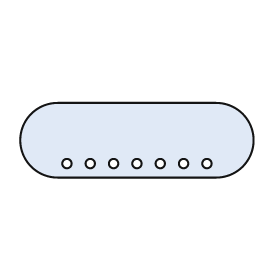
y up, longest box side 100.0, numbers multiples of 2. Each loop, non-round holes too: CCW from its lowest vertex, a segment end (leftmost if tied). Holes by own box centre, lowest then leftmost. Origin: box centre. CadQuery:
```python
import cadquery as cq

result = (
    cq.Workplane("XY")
    .moveTo(-34.0, -16.0)
    .lineTo(34.0, -16.0)
    .threePointArc((50.0, 0.0), (34.0, 16.0))
    .lineTo(-34.0, 16.0)
    .threePointArc((-50.0, 0.0), (-34.0, -16.0))
    .close()
    .moveTo(-30.0, -10.0)
    .circle(2.0)
    .moveTo(-20.0, -10.0)
    .circle(2.0)
    .moveTo(-10.0, -10.0)
    .circle(2.0)
    .moveTo(0.0, -10.0)
    .circle(2.0)
    .moveTo(10.0, -10.0)
    .circle(2.0)
    .moveTo(20.0, -10.0)
    .circle(2.0)
    .moveTo(30.0, -10.0)
    .circle(2.0)
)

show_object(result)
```